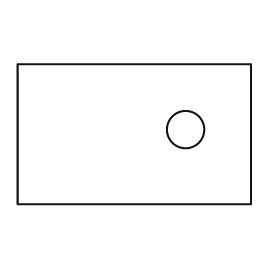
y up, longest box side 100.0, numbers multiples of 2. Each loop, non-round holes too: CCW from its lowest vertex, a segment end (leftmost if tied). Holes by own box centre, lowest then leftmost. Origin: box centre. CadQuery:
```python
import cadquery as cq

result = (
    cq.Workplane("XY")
    .moveTo(-50.0, -30.0)
    .lineTo(50.0, -30.0)
    .lineTo(50.0, 30.0)
    .lineTo(-50.0, 30.0)
    .close()
    .moveTo(22.0, 2.0)
    .circle(8.0)
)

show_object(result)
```